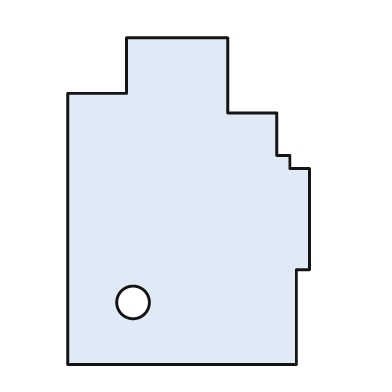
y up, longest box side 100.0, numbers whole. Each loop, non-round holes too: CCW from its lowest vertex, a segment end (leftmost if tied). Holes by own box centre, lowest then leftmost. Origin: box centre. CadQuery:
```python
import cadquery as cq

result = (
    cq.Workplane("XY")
    .moveTo(-37.0, -50.0)
    .lineTo(33.0, -50.0)
    .lineTo(33.0, -21.0)
    .lineTo(37.0, -21.0)
    .lineTo(37.0, 10.0)
    .lineTo(31.0, 10.0)
    .lineTo(31.0, 14.0)
    .lineTo(27.0, 14.0)
    .lineTo(27.0, 27.0)
    .lineTo(12.0, 27.0)
    .lineTo(12.0, 50.0)
    .lineTo(-19.0, 50.0)
    .lineTo(-19.0, 33.0)
    .lineTo(-37.0, 33.0)
    .close()
    .moveTo(-17.0, -31.0)
    .circle(5.0)
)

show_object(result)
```